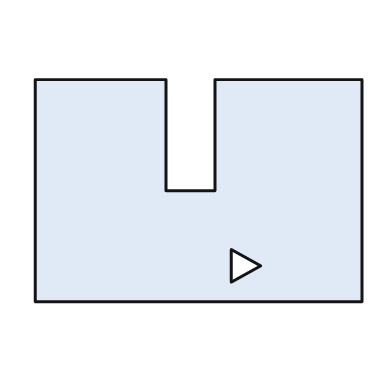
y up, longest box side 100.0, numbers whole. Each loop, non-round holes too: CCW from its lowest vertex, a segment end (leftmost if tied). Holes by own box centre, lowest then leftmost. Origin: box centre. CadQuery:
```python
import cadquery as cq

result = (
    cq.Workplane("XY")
    .moveTo(-50.0, -34.0)
    .lineTo(50.0, -34.0)
    .lineTo(50.0, 34.0)
    .lineTo(5.0, 34.0)
    .lineTo(5.0, 0.0)
    .lineTo(-10.0, 0.0)
    .lineTo(-10.0, 34.0)
    .lineTo(-50.0, 34.0)
    .close()
    .moveTo(10.0, -28.0)
    .lineTo(19.0, -23.0)
    .lineTo(10.0, -18.0)
    .close()
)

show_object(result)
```